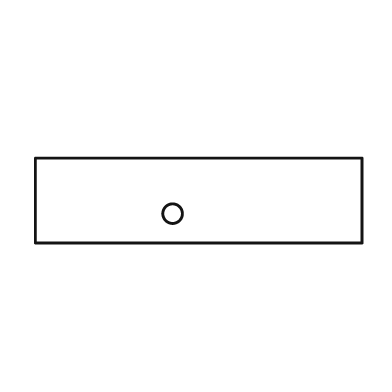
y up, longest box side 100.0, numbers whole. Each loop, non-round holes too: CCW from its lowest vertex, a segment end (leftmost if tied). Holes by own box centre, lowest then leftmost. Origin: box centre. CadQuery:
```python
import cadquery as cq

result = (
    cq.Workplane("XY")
    .moveTo(-50.0, -13.0)
    .lineTo(50.0, -13.0)
    .lineTo(50.0, 13.0)
    .lineTo(-50.0, 13.0)
    .close()
    .moveTo(-8.0, -4.0)
    .circle(3.0)
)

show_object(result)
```